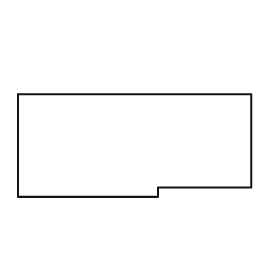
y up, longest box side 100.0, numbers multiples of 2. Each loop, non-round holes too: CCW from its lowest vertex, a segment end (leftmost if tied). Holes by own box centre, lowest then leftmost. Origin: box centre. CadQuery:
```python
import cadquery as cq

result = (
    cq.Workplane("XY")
    .moveTo(-50.0, -22.0)
    .lineTo(10.0, -22.0)
    .lineTo(10.0, -18.0)
    .lineTo(50.0, -18.0)
    .lineTo(50.0, 22.0)
    .lineTo(-50.0, 22.0)
    .close()
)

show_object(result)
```